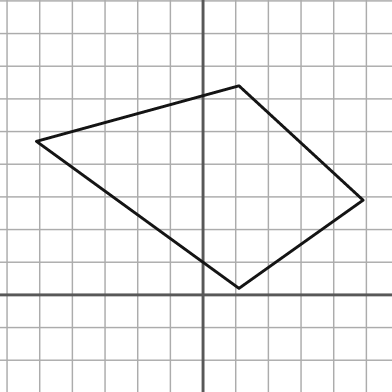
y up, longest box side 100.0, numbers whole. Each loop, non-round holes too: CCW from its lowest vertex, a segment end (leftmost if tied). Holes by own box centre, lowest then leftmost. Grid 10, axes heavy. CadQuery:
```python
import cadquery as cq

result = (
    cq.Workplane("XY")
    .moveTo(11.0, 2.0)
    .lineTo(49.0, 29.0)
    .lineTo(11.0, 64.0)
    .lineTo(-51.0, 47.0)
    .close()
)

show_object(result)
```